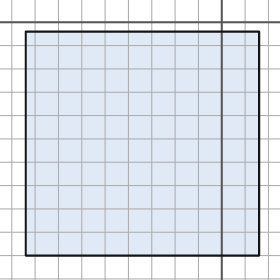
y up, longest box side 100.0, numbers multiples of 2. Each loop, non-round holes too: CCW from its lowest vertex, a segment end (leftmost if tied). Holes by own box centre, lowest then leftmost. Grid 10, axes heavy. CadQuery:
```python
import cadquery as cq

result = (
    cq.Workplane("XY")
    .moveTo(-84.0, -100.0)
    .lineTo(16.0, -100.0)
    .lineTo(16.0, -4.0)
    .lineTo(-84.0, -4.0)
    .close()
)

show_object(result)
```